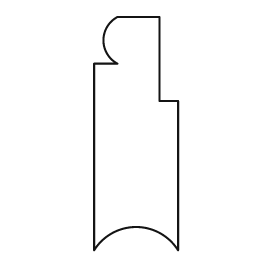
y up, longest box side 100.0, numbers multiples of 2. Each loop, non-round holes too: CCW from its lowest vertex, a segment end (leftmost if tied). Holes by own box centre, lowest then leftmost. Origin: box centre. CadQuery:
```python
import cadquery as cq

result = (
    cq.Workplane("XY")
    .moveTo(-18.0, -50.0)
    .threePointArc((0.0, -40.0), (18.0, -50.0))
    .lineTo(18.0, 14.0)
    .lineTo(10.0, 14.0)
    .lineTo(10.0, 50.0)
    .lineTo(-8.0, 50.0)
    .threePointArc((-14.0, 40.0), (-8.0, 30.0))
    .lineTo(-18.0, 30.0)
    .close()
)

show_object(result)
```